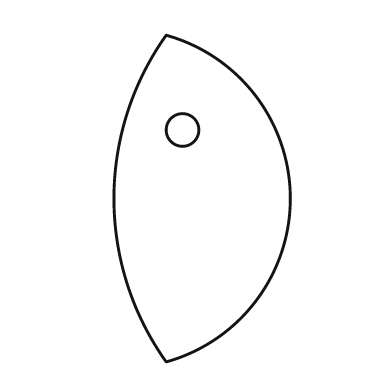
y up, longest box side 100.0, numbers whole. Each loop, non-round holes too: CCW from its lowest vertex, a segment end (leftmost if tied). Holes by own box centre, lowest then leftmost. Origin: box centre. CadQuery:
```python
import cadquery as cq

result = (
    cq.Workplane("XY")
    .moveTo(-11.0, -50.0)
    .threePointArc((27.0, 0.0), (-11.0, 50.0))
    .threePointArc((-27.0, 0.0), (-11.0, -50.0))
    .close()
    .moveTo(-6.0, 21.0)
    .circle(5.0)
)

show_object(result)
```